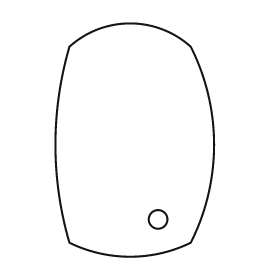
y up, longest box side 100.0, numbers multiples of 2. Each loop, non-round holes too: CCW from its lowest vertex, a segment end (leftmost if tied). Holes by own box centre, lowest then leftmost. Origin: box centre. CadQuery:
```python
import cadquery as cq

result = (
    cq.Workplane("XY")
    .moveTo(-28.0, -44.0)
    .threePointArc((-2.0, -50.0), (24.0, -44.0))
    .threePointArc((34.0, -2.0), (24.0, 40.0))
    .threePointArc((-2.0, 50.0), (-28.0, 40.0))
    .threePointArc((-34.0, -2.0), (-28.0, -44.0))
    .close()
    .moveTo(10.0, -34.0)
    .circle(4.0)
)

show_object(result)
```